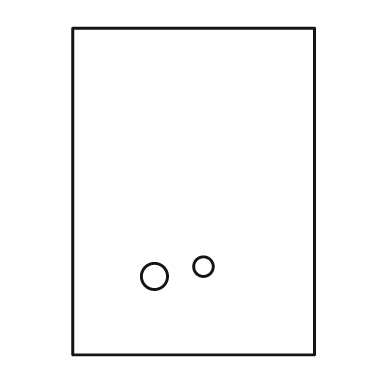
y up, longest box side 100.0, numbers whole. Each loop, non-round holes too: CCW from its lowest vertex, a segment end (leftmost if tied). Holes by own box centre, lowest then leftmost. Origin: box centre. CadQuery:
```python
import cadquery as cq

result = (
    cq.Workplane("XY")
    .moveTo(-37.0, -50.0)
    .lineTo(37.0, -50.0)
    .lineTo(37.0, 50.0)
    .lineTo(-37.0, 50.0)
    .close()
    .moveTo(-12.0, -26.0)
    .circle(4.0)
    .moveTo(3.0, -23.0)
    .circle(3.0)
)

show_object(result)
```